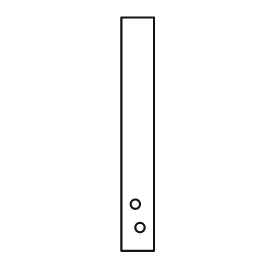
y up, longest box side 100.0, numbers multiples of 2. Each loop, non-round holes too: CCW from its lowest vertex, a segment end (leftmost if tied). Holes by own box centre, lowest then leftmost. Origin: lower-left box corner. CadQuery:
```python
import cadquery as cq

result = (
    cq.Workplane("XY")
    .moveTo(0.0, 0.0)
    .lineTo(14.0, 0.0)
    .lineTo(14.0, 100.0)
    .lineTo(0.0, 100.0)
    .close()
    .moveTo(8.0, 10.0)
    .circle(2.0)
    .moveTo(6.0, 20.0)
    .circle(2.0)
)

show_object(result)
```